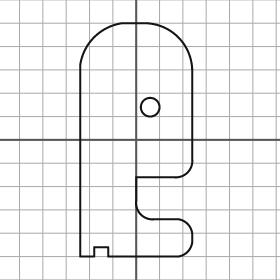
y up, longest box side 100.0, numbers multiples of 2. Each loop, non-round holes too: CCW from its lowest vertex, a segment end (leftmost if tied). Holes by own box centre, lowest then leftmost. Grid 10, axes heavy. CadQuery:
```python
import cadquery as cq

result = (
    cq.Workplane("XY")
    .moveTo(-24.0, -50.0)
    .lineTo(-18.0, -50.0)
    .lineTo(-18.0, -46.0)
    .lineTo(-12.0, -46.0)
    .lineTo(-12.0, -50.0)
    .lineTo(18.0, -50.0)
    .threePointArc((22.0, -48.0), (24.0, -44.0))
    .lineTo(24.0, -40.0)
    .threePointArc((22.0, -36.0), (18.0, -34.0))
    .lineTo(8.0, -34.0)
    .threePointArc((2.0, -32.0), (0.0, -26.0))
    .lineTo(0.0, -16.0)
    .lineTo(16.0, -16.0)
    .threePointArc((22.0, -14.0), (24.0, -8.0))
    .lineTo(24.0, 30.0)
    .threePointArc((18.0, 44.0), (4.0, 50.0))
    .lineTo(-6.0, 50.0)
    .threePointArc((-18.0, 44.0), (-24.0, 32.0))
    .close()
    .moveTo(6.0, 14.0)
    .circle(4.0)
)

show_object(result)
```